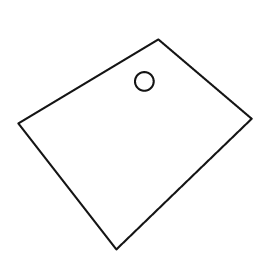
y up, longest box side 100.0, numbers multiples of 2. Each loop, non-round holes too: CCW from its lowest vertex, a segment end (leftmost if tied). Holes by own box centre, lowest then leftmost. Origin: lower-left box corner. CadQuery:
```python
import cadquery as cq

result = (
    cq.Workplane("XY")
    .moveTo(42.0, 0.0)
    .lineTo(100.0, 56.0)
    .lineTo(60.0, 90.0)
    .lineTo(0.0, 54.0)
    .close()
    .moveTo(54.0, 72.0)
    .circle(4.0)
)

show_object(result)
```